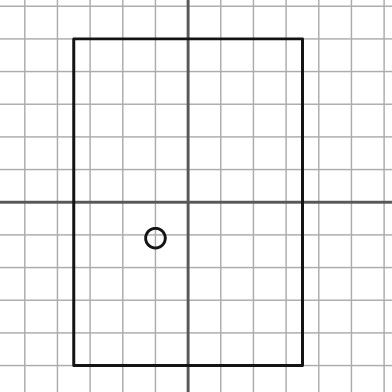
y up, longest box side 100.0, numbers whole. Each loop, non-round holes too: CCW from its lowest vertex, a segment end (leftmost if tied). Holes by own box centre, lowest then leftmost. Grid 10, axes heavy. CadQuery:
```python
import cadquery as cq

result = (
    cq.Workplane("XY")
    .moveTo(-35.0, -50.0)
    .lineTo(35.0, -50.0)
    .lineTo(35.0, 50.0)
    .lineTo(-35.0, 50.0)
    .close()
    .moveTo(-10.0, -11.0)
    .circle(3.0)
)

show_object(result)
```